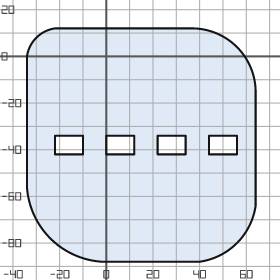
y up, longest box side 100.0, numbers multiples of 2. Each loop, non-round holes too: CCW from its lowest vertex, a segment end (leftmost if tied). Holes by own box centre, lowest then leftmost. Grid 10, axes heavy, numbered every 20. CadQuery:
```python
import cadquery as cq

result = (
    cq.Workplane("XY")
    .moveTo(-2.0, -88.0)
    .lineTo(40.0, -88.0)
    .threePointArc((56.0, -80.0), (64.0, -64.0))
    .lineTo(64.0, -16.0)
    .threePointArc((56.0, 4.0), (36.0, 12.0))
    .lineTo(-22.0, 12.0)
    .threePointArc((-30.0, 8.0), (-34.0, 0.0))
    .lineTo(-34.0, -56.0)
    .threePointArc((-24.0, -78.0), (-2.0, -88.0))
    .close()
    .moveTo(-22.0, -42.0)
    .lineTo(-10.0, -42.0)
    .lineTo(-10.0, -34.0)
    .lineTo(-22.0, -34.0)
    .close()
    .moveTo(0.0, -42.0)
    .lineTo(12.0, -42.0)
    .lineTo(12.0, -34.0)
    .lineTo(0.0, -34.0)
    .close()
    .moveTo(22.0, -42.0)
    .lineTo(34.0, -42.0)
    .lineTo(34.0, -34.0)
    .lineTo(22.0, -34.0)
    .close()
    .moveTo(44.0, -42.0)
    .lineTo(56.0, -42.0)
    .lineTo(56.0, -34.0)
    .lineTo(44.0, -34.0)
    .close()
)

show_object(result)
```